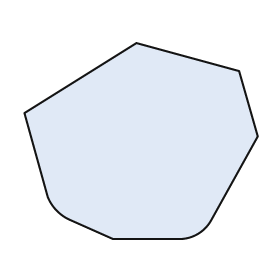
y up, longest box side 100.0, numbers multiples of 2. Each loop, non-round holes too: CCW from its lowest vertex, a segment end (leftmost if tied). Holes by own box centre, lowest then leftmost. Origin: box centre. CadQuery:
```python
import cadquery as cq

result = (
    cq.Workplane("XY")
    .moveTo(-12.0, -42.0)
    .lineTo(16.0, -42.0)
    .threePointArc((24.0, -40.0), (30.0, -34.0))
    .lineTo(50.0, 2.0)
    .lineTo(42.0, 30.0)
    .lineTo(-2.0, 42.0)
    .lineTo(-50.0, 12.0)
    .lineTo(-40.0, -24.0)
    .threePointArc((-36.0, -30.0), (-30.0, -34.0))
    .close()
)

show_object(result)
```